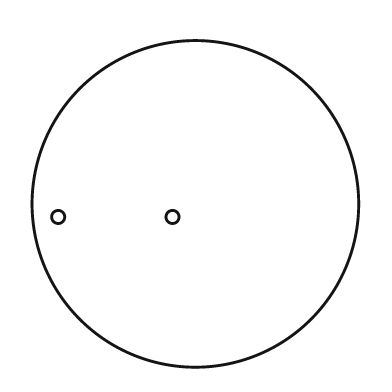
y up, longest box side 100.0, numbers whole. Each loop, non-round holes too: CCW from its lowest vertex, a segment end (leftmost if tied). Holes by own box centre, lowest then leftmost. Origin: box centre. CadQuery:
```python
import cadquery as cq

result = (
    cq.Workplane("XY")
    .moveTo(0.0, 0.0)
    .circle(50.0)
    .moveTo(-42.0, -4.0)
    .circle(2.0)
    .moveTo(-7.0, -4.0)
    .circle(2.0)
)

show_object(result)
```